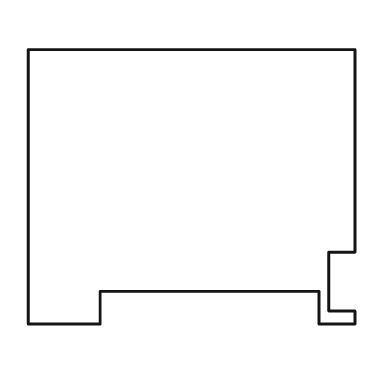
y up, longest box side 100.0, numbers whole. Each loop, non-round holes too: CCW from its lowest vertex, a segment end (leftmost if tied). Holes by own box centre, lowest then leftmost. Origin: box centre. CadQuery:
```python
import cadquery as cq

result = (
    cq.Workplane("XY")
    .moveTo(-50.0, -42.0)
    .lineTo(-28.0, -42.0)
    .lineTo(-28.0, -32.0)
    .lineTo(39.0, -32.0)
    .lineTo(39.0, -42.0)
    .lineTo(50.0, -42.0)
    .lineTo(50.0, -38.0)
    .lineTo(42.0, -38.0)
    .lineTo(42.0, -20.0)
    .lineTo(50.0, -20.0)
    .lineTo(50.0, 42.0)
    .lineTo(-50.0, 42.0)
    .close()
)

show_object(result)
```